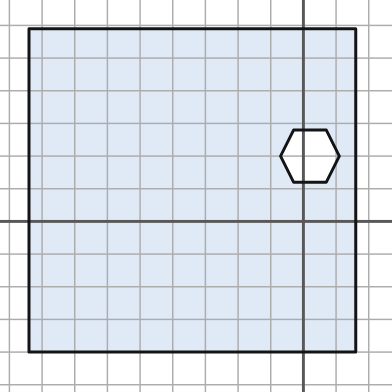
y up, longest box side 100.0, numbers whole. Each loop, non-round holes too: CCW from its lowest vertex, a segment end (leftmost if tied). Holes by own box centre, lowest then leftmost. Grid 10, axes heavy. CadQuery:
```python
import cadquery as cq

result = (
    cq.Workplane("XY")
    .moveTo(-84.0, -40.0)
    .lineTo(16.0, -40.0)
    .lineTo(16.0, 59.0)
    .lineTo(-84.0, 59.0)
    .close()
    .moveTo(-3.0, 12.0)
    .lineTo(7.0, 12.0)
    .lineTo(11.0, 20.0)
    .lineTo(7.0, 28.0)
    .lineTo(-3.0, 28.0)
    .lineTo(-7.0, 20.0)
    .close()
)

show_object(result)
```